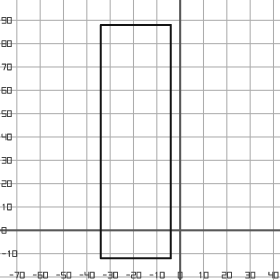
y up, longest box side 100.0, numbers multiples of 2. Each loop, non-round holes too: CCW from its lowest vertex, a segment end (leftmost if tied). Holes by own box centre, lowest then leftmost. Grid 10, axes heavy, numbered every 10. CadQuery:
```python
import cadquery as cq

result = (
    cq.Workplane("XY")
    .moveTo(-34.0, -12.0)
    .lineTo(-4.0, -12.0)
    .lineTo(-4.0, 88.0)
    .lineTo(-34.0, 88.0)
    .close()
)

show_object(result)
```